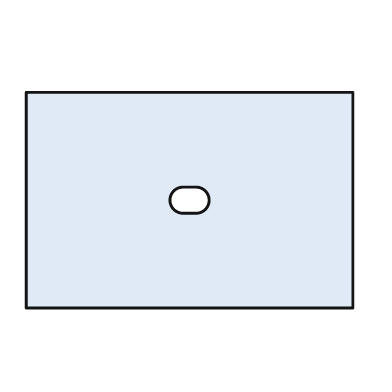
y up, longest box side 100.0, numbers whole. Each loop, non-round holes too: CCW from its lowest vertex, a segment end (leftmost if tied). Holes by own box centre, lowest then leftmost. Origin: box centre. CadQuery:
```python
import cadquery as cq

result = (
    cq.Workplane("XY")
    .moveTo(-50.0, -33.0)
    .lineTo(50.0, -33.0)
    .lineTo(50.0, 33.0)
    .lineTo(-50.0, 33.0)
    .close()
    .moveTo(-2.0, -4.0)
    .lineTo(2.0, -4.0)
    .threePointArc((6.0, 0.0), (2.0, 4.0))
    .lineTo(-2.0, 4.0)
    .threePointArc((-6.0, 0.0), (-2.0, -4.0))
    .close()
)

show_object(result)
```